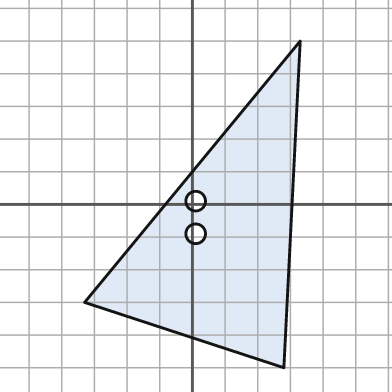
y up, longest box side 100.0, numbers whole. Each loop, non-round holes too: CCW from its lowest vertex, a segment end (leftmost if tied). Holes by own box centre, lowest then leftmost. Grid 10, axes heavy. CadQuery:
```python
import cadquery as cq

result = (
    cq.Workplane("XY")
    .moveTo(28.0, -50.0)
    .lineTo(33.0, 50.0)
    .lineTo(-33.0, -30.0)
    .close()
    .moveTo(1.0, -9.0)
    .circle(3.0)
    .moveTo(1.0, 1.0)
    .circle(3.0)
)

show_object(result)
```